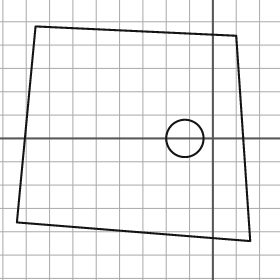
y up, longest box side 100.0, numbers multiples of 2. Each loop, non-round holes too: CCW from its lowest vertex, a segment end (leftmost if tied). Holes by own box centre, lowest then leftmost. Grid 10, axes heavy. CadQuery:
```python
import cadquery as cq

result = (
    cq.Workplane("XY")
    .moveTo(16.0, -44.0)
    .lineTo(10.0, 44.0)
    .lineTo(-76.0, 48.0)
    .lineTo(-84.0, -36.0)
    .close()
    .moveTo(-12.0, 0.0)
    .circle(8.0)
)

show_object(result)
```